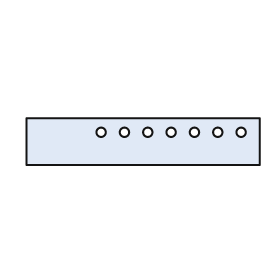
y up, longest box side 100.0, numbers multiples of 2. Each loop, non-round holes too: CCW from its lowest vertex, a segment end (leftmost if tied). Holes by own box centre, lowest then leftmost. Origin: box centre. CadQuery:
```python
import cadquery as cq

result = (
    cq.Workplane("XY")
    .moveTo(-50.0, -10.0)
    .lineTo(50.0, -10.0)
    .lineTo(50.0, 10.0)
    .lineTo(-50.0, 10.0)
    .close()
    .moveTo(-18.0, 4.0)
    .circle(2.0)
    .moveTo(-8.0, 4.0)
    .circle(2.0)
    .moveTo(2.0, 4.0)
    .circle(2.0)
    .moveTo(12.0, 4.0)
    .circle(2.0)
    .moveTo(22.0, 4.0)
    .circle(2.0)
    .moveTo(32.0, 4.0)
    .circle(2.0)
    .moveTo(42.0, 4.0)
    .circle(2.0)
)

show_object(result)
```